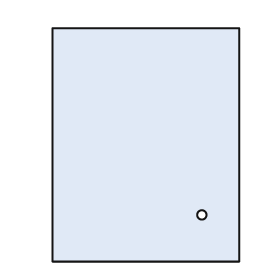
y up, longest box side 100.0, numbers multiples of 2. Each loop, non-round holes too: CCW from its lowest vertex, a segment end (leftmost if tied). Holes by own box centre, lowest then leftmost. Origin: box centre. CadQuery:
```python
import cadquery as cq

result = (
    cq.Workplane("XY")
    .moveTo(-40.0, -50.0)
    .lineTo(40.0, -50.0)
    .lineTo(40.0, 50.0)
    .lineTo(-40.0, 50.0)
    .close()
    .moveTo(24.0, -30.0)
    .circle(2.0)
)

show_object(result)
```